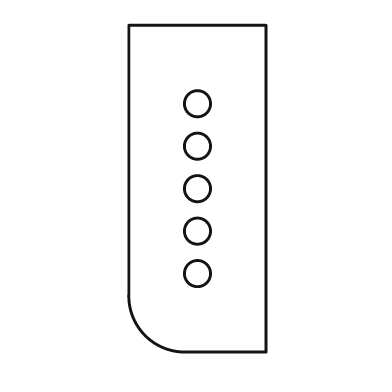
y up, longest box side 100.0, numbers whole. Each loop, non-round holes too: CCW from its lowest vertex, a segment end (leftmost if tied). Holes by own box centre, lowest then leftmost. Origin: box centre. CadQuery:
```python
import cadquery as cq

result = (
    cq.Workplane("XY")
    .moveTo(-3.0, -50.0)
    .lineTo(21.0, -50.0)
    .lineTo(21.0, 50.0)
    .lineTo(-21.0, 50.0)
    .lineTo(-21.0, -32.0)
    .threePointArc((-16.0, -45.0), (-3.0, -50.0))
    .close()
    .moveTo(0.0, -26.0)
    .circle(4.0)
    .moveTo(0.0, -13.0)
    .circle(4.0)
    .moveTo(0.0, 0.0)
    .circle(4.0)
    .moveTo(0.0, 13.0)
    .circle(4.0)
    .moveTo(0.0, 26.0)
    .circle(4.0)
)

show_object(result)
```